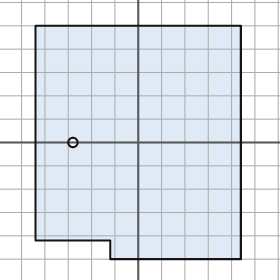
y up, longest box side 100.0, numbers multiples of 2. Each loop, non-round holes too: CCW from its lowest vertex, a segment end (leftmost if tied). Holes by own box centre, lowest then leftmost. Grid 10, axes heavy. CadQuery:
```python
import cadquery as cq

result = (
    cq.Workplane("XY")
    .moveTo(-12.0, -50.0)
    .lineTo(44.0, -50.0)
    .lineTo(44.0, 50.0)
    .lineTo(-44.0, 50.0)
    .lineTo(-44.0, -42.0)
    .lineTo(-12.0, -42.0)
    .close()
    .moveTo(-28.0, 0.0)
    .circle(2.0)
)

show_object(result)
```